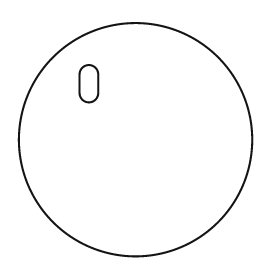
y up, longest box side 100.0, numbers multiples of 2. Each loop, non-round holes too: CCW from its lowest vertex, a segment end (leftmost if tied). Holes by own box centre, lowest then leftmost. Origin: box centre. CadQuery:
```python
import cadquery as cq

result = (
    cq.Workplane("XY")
    .moveTo(0.0, 0.0)
    .circle(50.0)
    .moveTo(-24.0, 20.0)
    .threePointArc((-20.0, 16.0), (-16.0, 20.0))
    .lineTo(-16.0, 28.0)
    .threePointArc((-20.0, 32.0), (-24.0, 28.0))
    .close()
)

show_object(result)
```